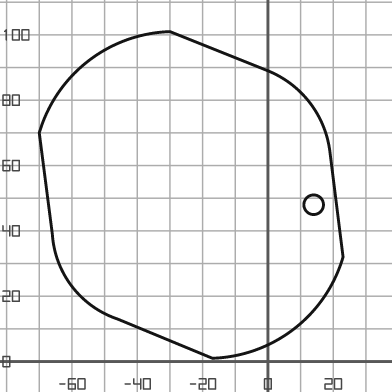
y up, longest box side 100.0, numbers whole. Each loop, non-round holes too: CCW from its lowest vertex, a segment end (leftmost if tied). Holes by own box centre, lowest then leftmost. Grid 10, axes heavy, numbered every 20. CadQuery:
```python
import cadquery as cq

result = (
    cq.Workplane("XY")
    .moveTo(-17.0, 1.0)
    .threePointArc((8.0, 10.0), (23.0, 32.0))
    .lineTo(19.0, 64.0)
    .threePointArc((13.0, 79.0), (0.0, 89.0))
    .lineTo(-30.0, 101.0)
    .threePointArc((-55.0, 92.0), (-70.0, 70.0))
    .lineTo(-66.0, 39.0)
    .threePointArc((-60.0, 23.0), (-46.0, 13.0))
    .close()
    .moveTo(14.0, 48.0)
    .circle(3.0)
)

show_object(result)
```